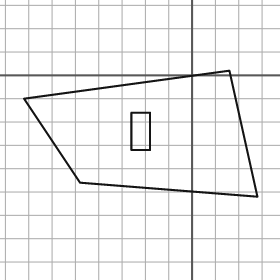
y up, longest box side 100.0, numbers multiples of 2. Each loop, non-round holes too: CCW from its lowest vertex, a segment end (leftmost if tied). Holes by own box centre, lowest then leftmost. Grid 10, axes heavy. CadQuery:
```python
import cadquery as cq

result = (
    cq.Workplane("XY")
    .moveTo(28.0, -52.0)
    .lineTo(16.0, 2.0)
    .lineTo(-72.0, -10.0)
    .lineTo(-48.0, -46.0)
    .close()
    .moveTo(-26.0, -32.0)
    .lineTo(-18.0, -32.0)
    .lineTo(-18.0, -16.0)
    .lineTo(-26.0, -16.0)
    .close()
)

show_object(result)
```